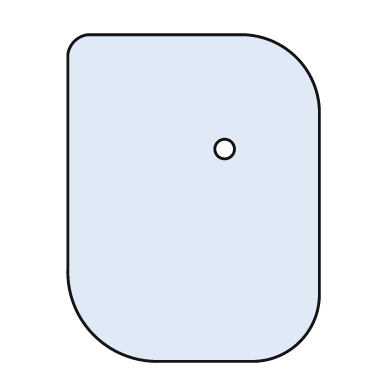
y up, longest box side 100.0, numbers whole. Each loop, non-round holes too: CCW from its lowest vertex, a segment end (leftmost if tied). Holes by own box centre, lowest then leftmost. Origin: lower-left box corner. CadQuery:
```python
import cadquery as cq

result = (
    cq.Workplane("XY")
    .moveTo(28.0, 0.0)
    .lineTo(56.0, 0.0)
    .threePointArc((71.0, 6.0), (77.0, 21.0))
    .lineTo(77.0, 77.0)
    .threePointArc((70.0, 93.0), (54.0, 100.0))
    .lineTo(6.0, 100.0)
    .threePointArc((2.0, 98.0), (0.0, 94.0))
    .lineTo(0.0, 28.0)
    .threePointArc((8.0, 8.0), (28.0, 0.0))
    .close()
    .moveTo(48.0, 65.0)
    .circle(3.0)
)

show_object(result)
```